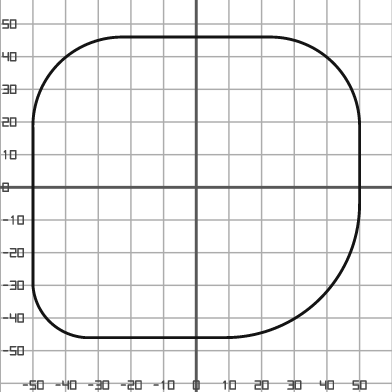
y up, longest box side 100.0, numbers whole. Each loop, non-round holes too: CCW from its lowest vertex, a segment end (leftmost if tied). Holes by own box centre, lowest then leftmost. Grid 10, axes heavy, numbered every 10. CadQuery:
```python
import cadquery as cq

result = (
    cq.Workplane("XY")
    .moveTo(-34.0, -46.0)
    .lineTo(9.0, -46.0)
    .threePointArc((38.0, -34.0), (50.0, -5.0))
    .lineTo(50.0, 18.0)
    .threePointArc((42.0, 38.0), (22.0, 46.0))
    .lineTo(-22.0, 46.0)
    .threePointArc((-42.0, 38.0), (-50.0, 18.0))
    .lineTo(-50.0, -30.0)
    .threePointArc((-45.0, -41.0), (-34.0, -46.0))
    .close()
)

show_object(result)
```